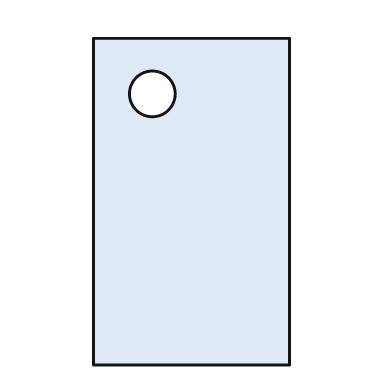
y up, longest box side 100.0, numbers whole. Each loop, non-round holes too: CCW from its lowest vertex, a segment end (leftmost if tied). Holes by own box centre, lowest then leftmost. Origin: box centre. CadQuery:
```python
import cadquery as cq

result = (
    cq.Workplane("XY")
    .moveTo(-30.0, -50.0)
    .lineTo(30.0, -50.0)
    .lineTo(30.0, 50.0)
    .lineTo(-30.0, 50.0)
    .close()
    .moveTo(-12.0, 33.0)
    .circle(7.0)
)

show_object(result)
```